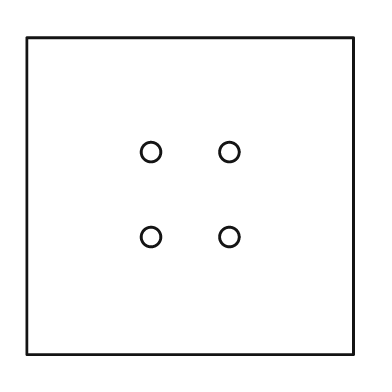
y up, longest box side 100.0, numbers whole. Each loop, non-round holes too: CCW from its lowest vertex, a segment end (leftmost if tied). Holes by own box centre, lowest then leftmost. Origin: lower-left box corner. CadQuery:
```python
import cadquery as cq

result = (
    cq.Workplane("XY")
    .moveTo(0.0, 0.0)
    .lineTo(100.0, 0.0)
    .lineTo(100.0, 97.0)
    .lineTo(0.0, 97.0)
    .close()
    .moveTo(38.0, 36.0)
    .circle(3.0)
    .moveTo(62.0, 36.0)
    .circle(3.0)
    .moveTo(38.0, 62.0)
    .circle(3.0)
    .moveTo(62.0, 62.0)
    .circle(3.0)
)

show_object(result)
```